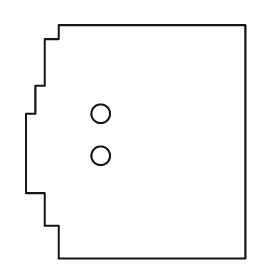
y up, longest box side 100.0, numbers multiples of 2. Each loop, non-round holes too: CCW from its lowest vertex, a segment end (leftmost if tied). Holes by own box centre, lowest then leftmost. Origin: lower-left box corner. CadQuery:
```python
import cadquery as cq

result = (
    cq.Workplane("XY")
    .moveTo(14.0, 0.0)
    .lineTo(94.0, 0.0)
    .lineTo(94.0, 100.0)
    .lineTo(14.0, 100.0)
    .lineTo(14.0, 94.0)
    .lineTo(8.0, 94.0)
    .lineTo(8.0, 74.0)
    .lineTo(4.0, 74.0)
    .lineTo(4.0, 62.0)
    .lineTo(0.0, 62.0)
    .lineTo(0.0, 28.0)
    .lineTo(8.0, 28.0)
    .lineTo(8.0, 14.0)
    .lineTo(14.0, 14.0)
    .close()
    .moveTo(32.0, 44.0)
    .circle(4.0)
    .moveTo(32.0, 62.0)
    .circle(4.0)
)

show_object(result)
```